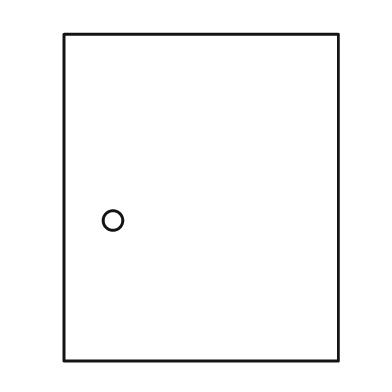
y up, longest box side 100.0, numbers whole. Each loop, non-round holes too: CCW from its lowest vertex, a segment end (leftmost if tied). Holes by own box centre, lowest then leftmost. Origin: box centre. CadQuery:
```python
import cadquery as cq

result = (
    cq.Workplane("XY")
    .moveTo(-42.0, -50.0)
    .lineTo(42.0, -50.0)
    .lineTo(42.0, 50.0)
    .lineTo(-42.0, 50.0)
    .close()
    .moveTo(-27.0, -7.0)
    .circle(3.0)
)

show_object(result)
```